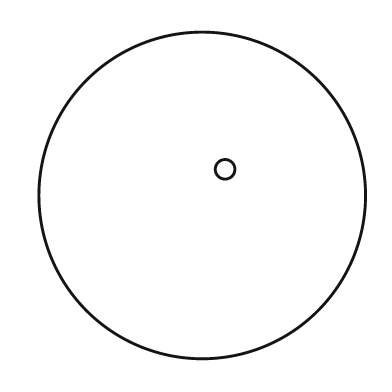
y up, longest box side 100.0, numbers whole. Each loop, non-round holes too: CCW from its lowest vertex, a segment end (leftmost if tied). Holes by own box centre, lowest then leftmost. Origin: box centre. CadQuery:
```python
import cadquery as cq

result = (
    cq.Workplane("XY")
    .moveTo(0.0, 0.0)
    .circle(50.0)
    .moveTo(7.0, 8.0)
    .circle(3.0)
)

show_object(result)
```